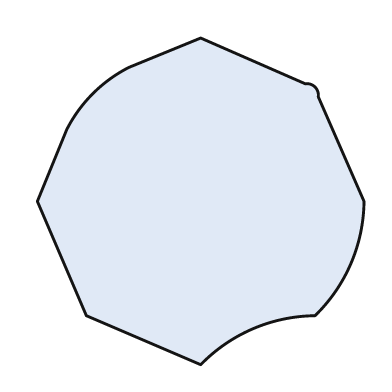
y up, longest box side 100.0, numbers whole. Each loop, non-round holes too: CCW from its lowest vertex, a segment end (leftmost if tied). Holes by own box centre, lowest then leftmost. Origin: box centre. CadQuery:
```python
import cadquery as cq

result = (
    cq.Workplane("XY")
    .moveTo(0.0, -50.0)
    .threePointArc((16.0, -39.0), (35.0, -35.0))
    .threePointArc((46.0, -19.0), (50.0, 0.0))
    .lineTo(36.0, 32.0)
    .threePointArc((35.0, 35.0), (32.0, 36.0))
    .lineTo(0.0, 50.0)
    .lineTo(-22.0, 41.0)
    .threePointArc((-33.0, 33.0), (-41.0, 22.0))
    .lineTo(-50.0, 0.0)
    .lineTo(-35.0, -35.0)
    .close()
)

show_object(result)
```